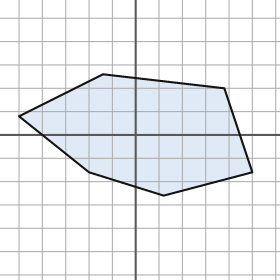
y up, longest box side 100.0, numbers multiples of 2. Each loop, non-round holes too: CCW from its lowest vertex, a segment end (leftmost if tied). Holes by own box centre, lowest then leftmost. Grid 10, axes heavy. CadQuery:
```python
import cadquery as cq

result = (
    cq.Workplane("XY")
    .moveTo(12.0, -26.0)
    .lineTo(50.0, -16.0)
    .lineTo(38.0, 20.0)
    .lineTo(-14.0, 26.0)
    .lineTo(-50.0, 8.0)
    .lineTo(-20.0, -16.0)
    .close()
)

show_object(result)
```